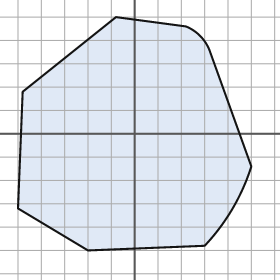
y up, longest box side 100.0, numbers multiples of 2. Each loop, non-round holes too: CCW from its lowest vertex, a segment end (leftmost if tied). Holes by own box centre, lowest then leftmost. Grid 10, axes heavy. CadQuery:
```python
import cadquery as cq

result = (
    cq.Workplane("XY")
    .moveTo(-20.0, -50.0)
    .lineTo(30.0, -48.0)
    .threePointArc((42.0, -32.0), (50.0, -14.0))
    .lineTo(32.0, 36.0)
    .threePointArc((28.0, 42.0), (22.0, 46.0))
    .lineTo(-8.0, 50.0)
    .lineTo(-48.0, 18.0)
    .lineTo(-50.0, -32.0)
    .close()
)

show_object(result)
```